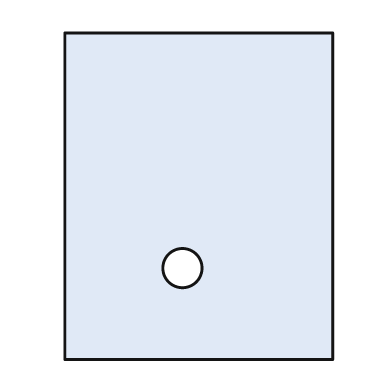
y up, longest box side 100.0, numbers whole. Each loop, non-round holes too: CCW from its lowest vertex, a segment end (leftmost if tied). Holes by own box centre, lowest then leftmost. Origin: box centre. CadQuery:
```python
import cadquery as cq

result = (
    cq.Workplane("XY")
    .moveTo(-41.0, -50.0)
    .lineTo(41.0, -50.0)
    .lineTo(41.0, 50.0)
    .lineTo(-41.0, 50.0)
    .close()
    .moveTo(-5.0, -22.0)
    .circle(6.0)
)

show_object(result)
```